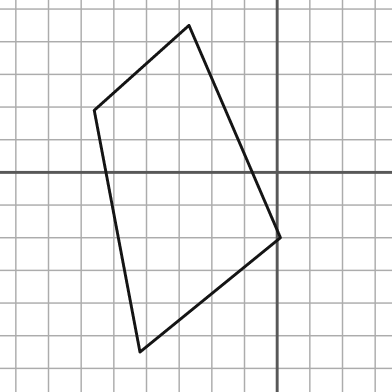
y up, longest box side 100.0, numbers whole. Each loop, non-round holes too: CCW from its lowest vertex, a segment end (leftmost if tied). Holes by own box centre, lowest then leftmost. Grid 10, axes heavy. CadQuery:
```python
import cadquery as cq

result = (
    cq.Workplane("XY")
    .moveTo(-42.0, -55.0)
    .lineTo(1.0, -20.0)
    .lineTo(-27.0, 45.0)
    .lineTo(-56.0, 19.0)
    .close()
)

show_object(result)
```